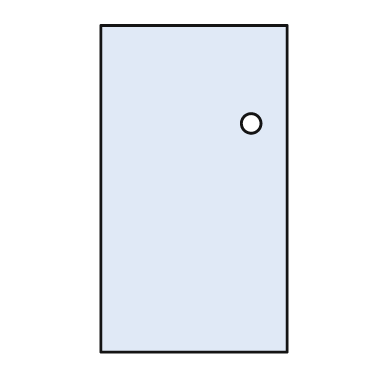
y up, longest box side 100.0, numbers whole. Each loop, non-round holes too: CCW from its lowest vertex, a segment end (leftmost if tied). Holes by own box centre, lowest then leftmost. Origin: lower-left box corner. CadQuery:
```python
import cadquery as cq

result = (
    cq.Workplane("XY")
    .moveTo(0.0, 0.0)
    .lineTo(57.0, 0.0)
    .lineTo(57.0, 100.0)
    .lineTo(0.0, 100.0)
    .close()
    .moveTo(46.0, 70.0)
    .circle(3.0)
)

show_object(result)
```